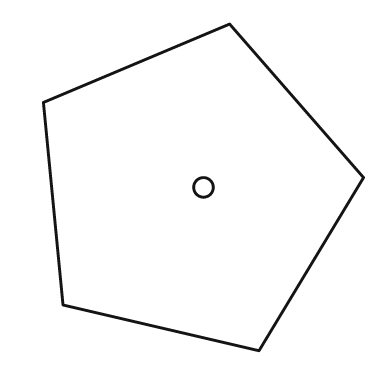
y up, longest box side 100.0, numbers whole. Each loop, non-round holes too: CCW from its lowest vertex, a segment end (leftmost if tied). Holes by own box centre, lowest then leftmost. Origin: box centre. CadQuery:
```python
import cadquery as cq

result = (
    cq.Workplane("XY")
    .moveTo(17.0, -50.0)
    .lineTo(49.0, 3.0)
    .lineTo(8.0, 50.0)
    .lineTo(-49.0, 26.0)
    .lineTo(-43.0, -36.0)
    .close()
    .moveTo(0.0, 0.0)
    .circle(3.0)
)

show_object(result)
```